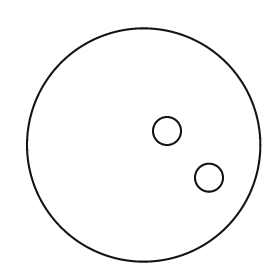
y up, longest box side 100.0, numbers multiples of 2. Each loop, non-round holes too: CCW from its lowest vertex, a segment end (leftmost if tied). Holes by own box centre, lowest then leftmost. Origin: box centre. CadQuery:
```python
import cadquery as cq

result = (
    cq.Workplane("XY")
    .moveTo(0.0, 0.0)
    .circle(50.0)
    .moveTo(28.0, -14.0)
    .circle(6.0)
    .moveTo(10.0, 6.0)
    .circle(6.0)
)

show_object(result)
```